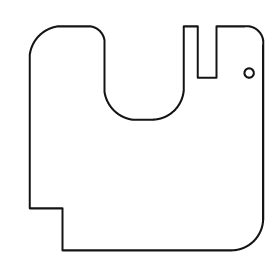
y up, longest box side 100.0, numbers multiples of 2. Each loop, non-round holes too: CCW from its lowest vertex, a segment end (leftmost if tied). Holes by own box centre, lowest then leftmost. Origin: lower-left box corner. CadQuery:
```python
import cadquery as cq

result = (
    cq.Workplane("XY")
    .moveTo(14.0, 0.0)
    .lineTo(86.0, 0.0)
    .threePointArc((96.0, 4.0), (100.0, 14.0))
    .lineTo(100.0, 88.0)
    .threePointArc((98.0, 94.0), (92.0, 96.0))
    .lineTo(80.0, 96.0)
    .lineTo(80.0, 74.0)
    .lineTo(72.0, 74.0)
    .lineTo(72.0, 96.0)
    .lineTo(66.0, 96.0)
    .lineTo(66.0, 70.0)
    .threePointArc((62.0, 60.0), (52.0, 56.0))
    .lineTo(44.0, 56.0)
    .threePointArc((36.0, 60.0), (32.0, 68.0))
    .lineTo(32.0, 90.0)
    .threePointArc((30.0, 94.0), (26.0, 96.0))
    .lineTo(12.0, 96.0)
    .threePointArc((4.0, 92.0), (0.0, 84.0))
    .lineTo(0.0, 18.0)
    .lineTo(14.0, 18.0)
    .close()
    .moveTo(94.0, 76.0)
    .circle(2.0)
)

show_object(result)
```